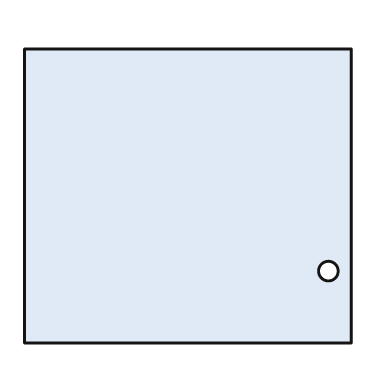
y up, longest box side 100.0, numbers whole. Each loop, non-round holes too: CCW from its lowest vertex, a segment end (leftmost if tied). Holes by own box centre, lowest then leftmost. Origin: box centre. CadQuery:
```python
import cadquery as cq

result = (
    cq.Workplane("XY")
    .moveTo(-50.0, -45.0)
    .lineTo(50.0, -45.0)
    .lineTo(50.0, 45.0)
    .lineTo(-50.0, 45.0)
    .close()
    .moveTo(43.0, -23.0)
    .circle(3.0)
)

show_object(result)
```